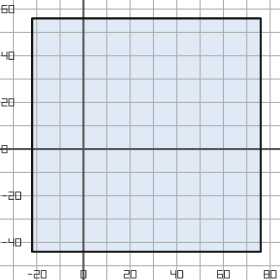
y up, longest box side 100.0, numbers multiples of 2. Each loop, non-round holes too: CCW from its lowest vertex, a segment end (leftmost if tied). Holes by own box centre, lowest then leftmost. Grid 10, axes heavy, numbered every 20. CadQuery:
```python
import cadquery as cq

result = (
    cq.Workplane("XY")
    .moveTo(-22.0, -44.0)
    .lineTo(76.0, -44.0)
    .lineTo(76.0, 56.0)
    .lineTo(-22.0, 56.0)
    .close()
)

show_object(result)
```